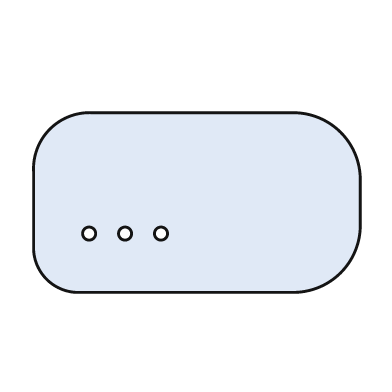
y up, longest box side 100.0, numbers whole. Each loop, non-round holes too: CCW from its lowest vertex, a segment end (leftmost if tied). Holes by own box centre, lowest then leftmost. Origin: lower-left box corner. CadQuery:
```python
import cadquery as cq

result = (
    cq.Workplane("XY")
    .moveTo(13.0, 0.0)
    .lineTo(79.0, 0.0)
    .threePointArc((94.0, 6.0), (100.0, 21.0))
    .lineTo(100.0, 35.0)
    .threePointArc((94.0, 49.0), (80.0, 55.0))
    .lineTo(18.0, 55.0)
    .threePointArc((5.0, 50.0), (0.0, 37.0))
    .lineTo(0.0, 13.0)
    .threePointArc((4.0, 4.0), (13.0, 0.0))
    .close()
    .moveTo(17.0, 18.0)
    .circle(2.0)
    .moveTo(28.0, 18.0)
    .circle(2.0)
    .moveTo(39.0, 18.0)
    .circle(2.0)
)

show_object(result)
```